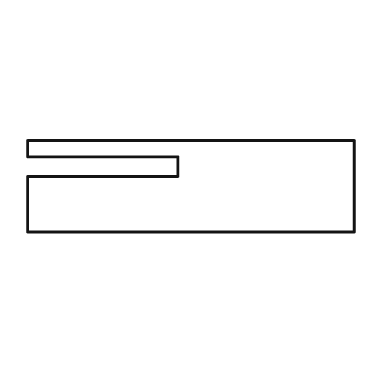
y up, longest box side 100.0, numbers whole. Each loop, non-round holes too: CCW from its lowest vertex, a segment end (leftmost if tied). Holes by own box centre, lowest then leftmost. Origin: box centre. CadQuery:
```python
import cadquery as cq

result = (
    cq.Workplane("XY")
    .moveTo(-50.0, -14.0)
    .lineTo(50.0, -14.0)
    .lineTo(50.0, 14.0)
    .lineTo(-50.0, 14.0)
    .lineTo(-50.0, 9.0)
    .lineTo(-4.0, 9.0)
    .lineTo(-4.0, 3.0)
    .lineTo(-50.0, 3.0)
    .close()
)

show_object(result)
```